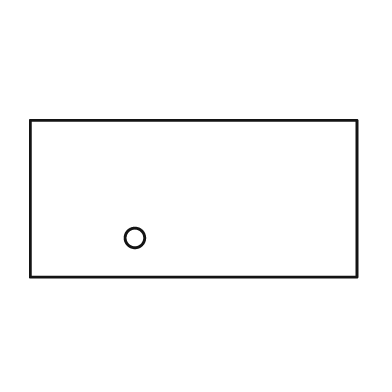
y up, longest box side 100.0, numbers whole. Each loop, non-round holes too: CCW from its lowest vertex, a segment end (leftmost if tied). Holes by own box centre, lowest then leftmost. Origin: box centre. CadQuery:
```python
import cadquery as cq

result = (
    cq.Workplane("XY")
    .moveTo(-50.0, -24.0)
    .lineTo(50.0, -24.0)
    .lineTo(50.0, 24.0)
    .lineTo(-50.0, 24.0)
    .close()
    .moveTo(-18.0, -12.0)
    .circle(3.0)
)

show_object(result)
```